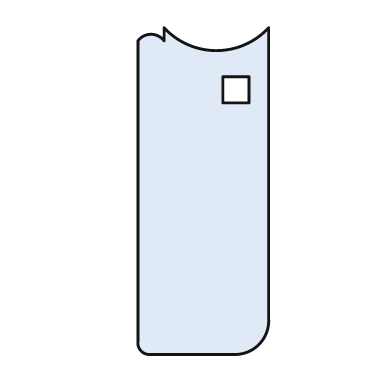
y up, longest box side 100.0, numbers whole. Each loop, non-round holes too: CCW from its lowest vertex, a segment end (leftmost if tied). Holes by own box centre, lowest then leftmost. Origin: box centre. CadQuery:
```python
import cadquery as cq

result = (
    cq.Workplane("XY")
    .moveTo(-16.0, -50.0)
    .lineTo(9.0, -50.0)
    .threePointArc((17.0, -47.0), (20.0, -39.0))
    .lineTo(20.0, 50.0)
    .threePointArc((4.0, 43.0), (-12.0, 50.0))
    .lineTo(-12.0, 46.0)
    .threePointArc((-16.0, 48.0), (-20.0, 46.0))
    .lineTo(-20.0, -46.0)
    .threePointArc((-19.0, -49.0), (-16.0, -50.0))
    .close()
    .moveTo(6.0, 27.0)
    .lineTo(14.0, 27.0)
    .lineTo(14.0, 35.0)
    .lineTo(6.0, 35.0)
    .close()
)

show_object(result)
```